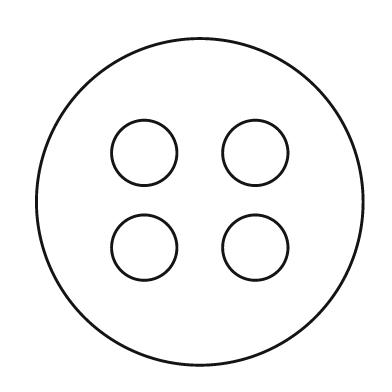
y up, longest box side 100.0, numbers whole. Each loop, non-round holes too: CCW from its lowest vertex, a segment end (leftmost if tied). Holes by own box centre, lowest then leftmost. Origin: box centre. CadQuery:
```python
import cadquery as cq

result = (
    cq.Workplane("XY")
    .moveTo(0.0, 0.0)
    .circle(50.0)
    .moveTo(-17.0, -14.0)
    .circle(10.0)
    .moveTo(17.0, -14.0)
    .circle(10.0)
    .moveTo(-17.0, 15.0)
    .circle(10.0)
    .moveTo(17.0, 15.0)
    .circle(10.0)
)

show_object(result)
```